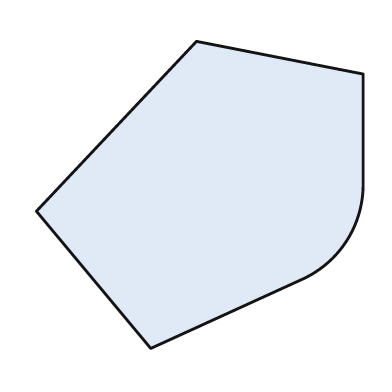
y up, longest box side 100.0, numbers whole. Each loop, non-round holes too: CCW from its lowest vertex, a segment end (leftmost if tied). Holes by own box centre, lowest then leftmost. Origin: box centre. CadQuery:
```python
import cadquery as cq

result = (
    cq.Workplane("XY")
    .moveTo(-15.0, -47.0)
    .lineTo(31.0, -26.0)
    .threePointArc((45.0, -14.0), (50.0, 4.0))
    .lineTo(50.0, 37.0)
    .lineTo(-1.0, 47.0)
    .lineTo(-50.0, -5.0)
    .close()
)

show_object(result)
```